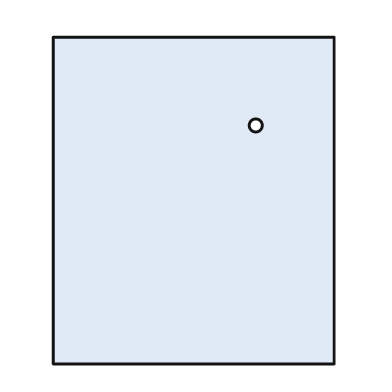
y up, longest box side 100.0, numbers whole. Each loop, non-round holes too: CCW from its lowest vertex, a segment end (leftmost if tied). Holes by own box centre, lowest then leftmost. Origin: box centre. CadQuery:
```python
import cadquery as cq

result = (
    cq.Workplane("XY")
    .moveTo(-43.0, -50.0)
    .lineTo(43.0, -50.0)
    .lineTo(43.0, 50.0)
    .lineTo(-43.0, 50.0)
    .close()
    .moveTo(19.0, 23.0)
    .circle(2.0)
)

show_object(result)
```